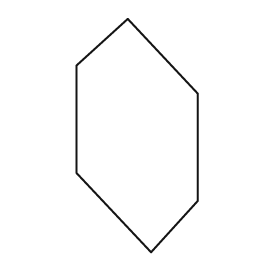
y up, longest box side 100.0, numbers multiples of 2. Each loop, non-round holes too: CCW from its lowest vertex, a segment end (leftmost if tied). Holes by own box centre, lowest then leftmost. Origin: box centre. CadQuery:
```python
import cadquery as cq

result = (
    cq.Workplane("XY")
    .moveTo(6.0, -50.0)
    .lineTo(26.0, -28.0)
    .lineTo(26.0, 18.0)
    .lineTo(-4.0, 50.0)
    .lineTo(-26.0, 30.0)
    .lineTo(-26.0, -16.0)
    .close()
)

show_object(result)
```